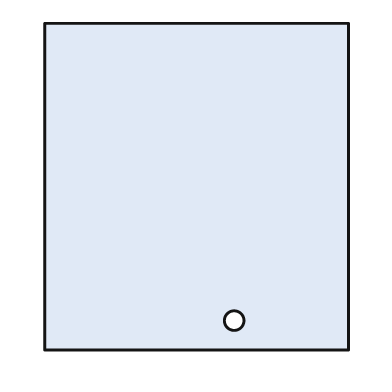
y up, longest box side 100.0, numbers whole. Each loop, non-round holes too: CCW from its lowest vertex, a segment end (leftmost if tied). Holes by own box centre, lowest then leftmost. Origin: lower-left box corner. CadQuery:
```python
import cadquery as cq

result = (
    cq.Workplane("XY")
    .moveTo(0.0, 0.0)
    .lineTo(93.0, 0.0)
    .lineTo(93.0, 100.0)
    .lineTo(0.0, 100.0)
    .close()
    .moveTo(58.0, 9.0)
    .circle(3.0)
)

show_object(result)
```